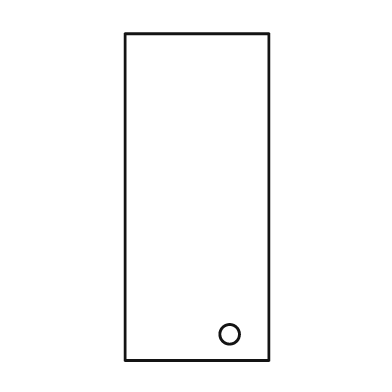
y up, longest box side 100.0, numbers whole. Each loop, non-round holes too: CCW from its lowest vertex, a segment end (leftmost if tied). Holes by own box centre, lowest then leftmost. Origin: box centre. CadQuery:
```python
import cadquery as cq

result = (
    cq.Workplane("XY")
    .moveTo(-22.0, -50.0)
    .lineTo(22.0, -50.0)
    .lineTo(22.0, 50.0)
    .lineTo(-22.0, 50.0)
    .close()
    .moveTo(10.0, -42.0)
    .circle(3.0)
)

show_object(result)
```